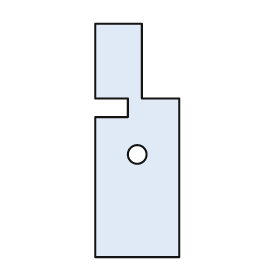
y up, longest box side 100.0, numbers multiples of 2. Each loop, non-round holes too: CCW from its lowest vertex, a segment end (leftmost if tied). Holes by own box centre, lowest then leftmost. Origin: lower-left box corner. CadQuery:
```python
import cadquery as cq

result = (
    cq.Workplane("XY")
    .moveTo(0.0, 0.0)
    .lineTo(36.0, 0.0)
    .lineTo(36.0, 68.0)
    .lineTo(20.0, 68.0)
    .lineTo(20.0, 100.0)
    .lineTo(0.0, 100.0)
    .lineTo(0.0, 68.0)
    .lineTo(14.0, 68.0)
    .lineTo(14.0, 60.0)
    .lineTo(0.0, 60.0)
    .close()
    .moveTo(18.0, 44.0)
    .circle(4.0)
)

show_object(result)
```